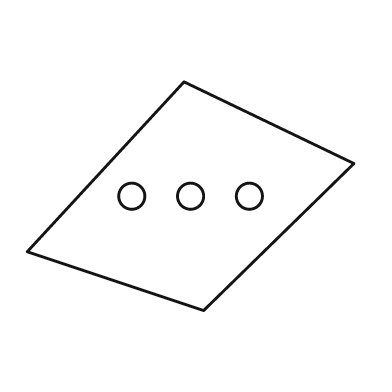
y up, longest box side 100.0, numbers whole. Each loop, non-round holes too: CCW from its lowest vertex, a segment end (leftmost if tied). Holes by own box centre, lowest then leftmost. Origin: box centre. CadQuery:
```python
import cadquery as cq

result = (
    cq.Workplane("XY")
    .moveTo(4.0, -35.0)
    .lineTo(50.0, 10.0)
    .lineTo(-2.0, 35.0)
    .lineTo(-50.0, -17.0)
    .close()
    .moveTo(-18.0, 0.0)
    .circle(4.0)
    .moveTo(0.0, 0.0)
    .circle(4.0)
    .moveTo(18.0, 0.0)
    .circle(4.0)
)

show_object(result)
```